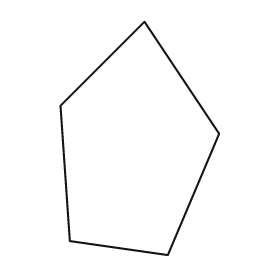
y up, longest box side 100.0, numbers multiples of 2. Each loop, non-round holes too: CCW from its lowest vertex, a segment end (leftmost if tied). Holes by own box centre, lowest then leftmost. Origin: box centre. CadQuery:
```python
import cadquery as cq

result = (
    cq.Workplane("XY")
    .moveTo(12.0, -50.0)
    .lineTo(34.0, 2.0)
    .lineTo(2.0, 50.0)
    .lineTo(-34.0, 14.0)
    .lineTo(-30.0, -44.0)
    .close()
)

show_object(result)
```